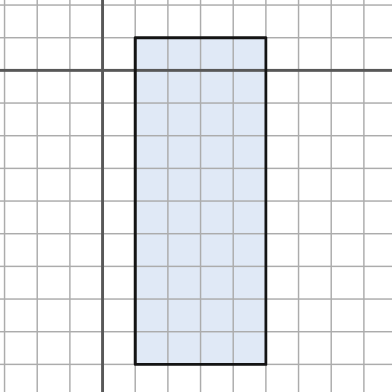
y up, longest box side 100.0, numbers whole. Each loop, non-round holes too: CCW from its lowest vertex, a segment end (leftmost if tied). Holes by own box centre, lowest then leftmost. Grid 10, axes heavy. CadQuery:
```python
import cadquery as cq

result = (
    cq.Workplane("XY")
    .moveTo(10.0, -90.0)
    .lineTo(50.0, -90.0)
    .lineTo(50.0, 10.0)
    .lineTo(10.0, 10.0)
    .close()
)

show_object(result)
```